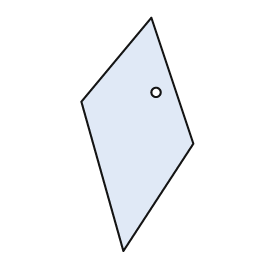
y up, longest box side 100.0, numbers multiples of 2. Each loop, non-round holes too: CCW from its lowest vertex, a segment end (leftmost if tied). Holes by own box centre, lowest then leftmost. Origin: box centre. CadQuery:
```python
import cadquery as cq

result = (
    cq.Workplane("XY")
    .moveTo(-6.0, -50.0)
    .lineTo(24.0, -4.0)
    .lineTo(6.0, 50.0)
    .lineTo(-24.0, 14.0)
    .close()
    .moveTo(8.0, 18.0)
    .circle(2.0)
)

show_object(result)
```